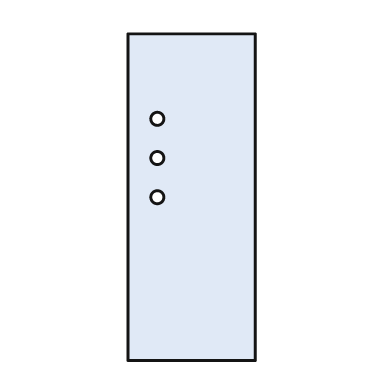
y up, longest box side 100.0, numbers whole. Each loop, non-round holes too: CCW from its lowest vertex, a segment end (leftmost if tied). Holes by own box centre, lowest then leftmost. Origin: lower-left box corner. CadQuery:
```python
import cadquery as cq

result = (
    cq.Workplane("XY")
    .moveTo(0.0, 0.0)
    .lineTo(39.0, 0.0)
    .lineTo(39.0, 100.0)
    .lineTo(0.0, 100.0)
    .close()
    .moveTo(9.0, 50.0)
    .circle(2.0)
    .moveTo(9.0, 62.0)
    .circle(2.0)
    .moveTo(9.0, 74.0)
    .circle(2.0)
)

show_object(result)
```